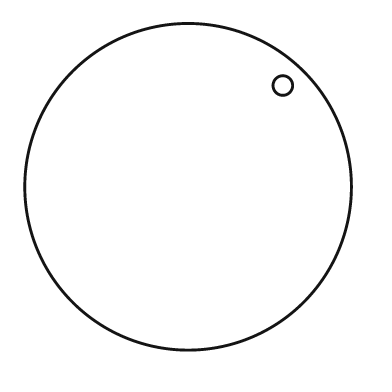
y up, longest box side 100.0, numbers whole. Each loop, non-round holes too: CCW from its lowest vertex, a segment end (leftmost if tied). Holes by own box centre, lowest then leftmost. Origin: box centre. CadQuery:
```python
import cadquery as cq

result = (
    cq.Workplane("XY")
    .moveTo(0.0, 0.0)
    .circle(50.0)
    .moveTo(29.0, 31.0)
    .circle(3.0)
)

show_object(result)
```